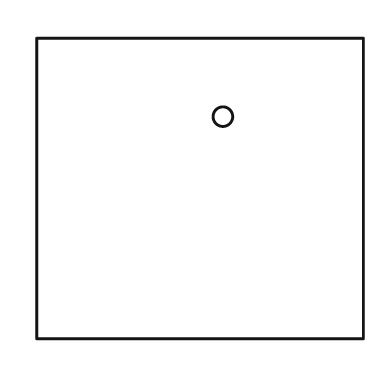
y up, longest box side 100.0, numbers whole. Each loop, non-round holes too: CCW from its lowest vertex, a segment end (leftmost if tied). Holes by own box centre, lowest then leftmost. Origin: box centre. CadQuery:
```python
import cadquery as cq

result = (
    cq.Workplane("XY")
    .moveTo(-50.0, -46.0)
    .lineTo(50.0, -46.0)
    .lineTo(50.0, 46.0)
    .lineTo(-50.0, 46.0)
    .close()
    .moveTo(7.0, 22.0)
    .circle(3.0)
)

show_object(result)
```